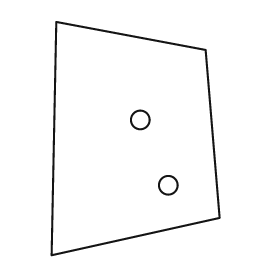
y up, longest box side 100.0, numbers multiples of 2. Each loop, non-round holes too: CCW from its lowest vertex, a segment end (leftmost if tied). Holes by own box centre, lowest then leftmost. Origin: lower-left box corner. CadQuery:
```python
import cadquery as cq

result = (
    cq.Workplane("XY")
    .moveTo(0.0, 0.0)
    .lineTo(72.0, 16.0)
    .lineTo(66.0, 88.0)
    .lineTo(2.0, 100.0)
    .close()
    .moveTo(50.0, 30.0)
    .circle(4.0)
    .moveTo(38.0, 58.0)
    .circle(4.0)
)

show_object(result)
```